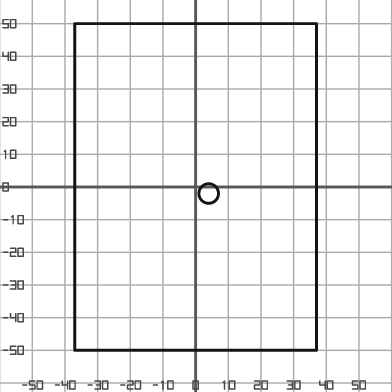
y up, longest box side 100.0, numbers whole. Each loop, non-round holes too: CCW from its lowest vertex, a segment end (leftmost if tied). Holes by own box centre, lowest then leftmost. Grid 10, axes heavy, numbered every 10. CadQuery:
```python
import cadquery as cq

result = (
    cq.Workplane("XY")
    .moveTo(-37.0, -50.0)
    .lineTo(37.0, -50.0)
    .lineTo(37.0, 50.0)
    .lineTo(-37.0, 50.0)
    .close()
    .moveTo(4.0, -2.0)
    .circle(3.0)
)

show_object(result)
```